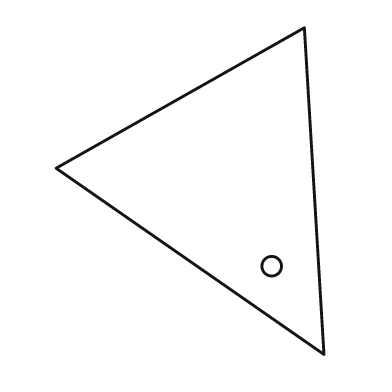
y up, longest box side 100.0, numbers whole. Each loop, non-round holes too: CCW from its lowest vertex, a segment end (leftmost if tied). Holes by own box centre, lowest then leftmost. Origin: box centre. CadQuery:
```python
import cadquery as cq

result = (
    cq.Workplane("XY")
    .moveTo(41.0, -50.0)
    .lineTo(35.0, 50.0)
    .lineTo(-41.0, 7.0)
    .close()
    .moveTo(25.0, -23.0)
    .circle(3.0)
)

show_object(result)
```